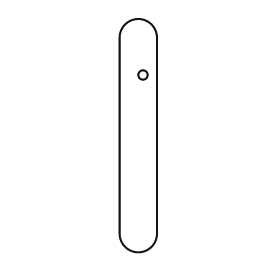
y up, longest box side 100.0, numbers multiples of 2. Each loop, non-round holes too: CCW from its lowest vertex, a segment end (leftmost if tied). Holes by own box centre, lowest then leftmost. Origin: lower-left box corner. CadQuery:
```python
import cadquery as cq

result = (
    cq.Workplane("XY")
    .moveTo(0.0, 8.0)
    .threePointArc((8.0, 0.0), (16.0, 8.0))
    .lineTo(16.0, 92.0)
    .threePointArc((8.0, 100.0), (0.0, 92.0))
    .close()
    .moveTo(10.0, 76.0)
    .circle(2.0)
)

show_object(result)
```